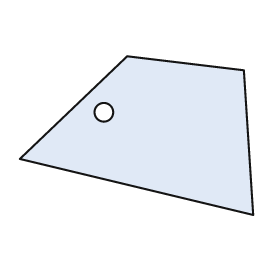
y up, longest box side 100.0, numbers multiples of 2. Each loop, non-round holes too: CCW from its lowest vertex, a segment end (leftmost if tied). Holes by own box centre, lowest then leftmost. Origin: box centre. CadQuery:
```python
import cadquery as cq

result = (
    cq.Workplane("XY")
    .moveTo(50.0, -34.0)
    .lineTo(46.0, 28.0)
    .lineTo(-4.0, 34.0)
    .lineTo(-50.0, -10.0)
    .close()
    .moveTo(-14.0, 10.0)
    .circle(4.0)
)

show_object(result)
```